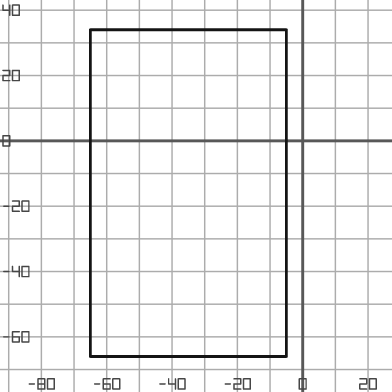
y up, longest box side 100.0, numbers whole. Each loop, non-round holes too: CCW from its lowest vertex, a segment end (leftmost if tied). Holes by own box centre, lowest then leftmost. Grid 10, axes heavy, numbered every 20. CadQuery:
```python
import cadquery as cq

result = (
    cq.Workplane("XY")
    .moveTo(-65.0, -66.0)
    .lineTo(-5.0, -66.0)
    .lineTo(-5.0, 34.0)
    .lineTo(-65.0, 34.0)
    .close()
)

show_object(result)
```